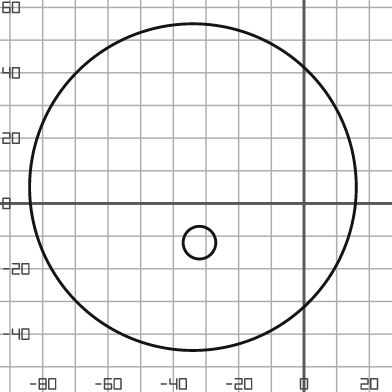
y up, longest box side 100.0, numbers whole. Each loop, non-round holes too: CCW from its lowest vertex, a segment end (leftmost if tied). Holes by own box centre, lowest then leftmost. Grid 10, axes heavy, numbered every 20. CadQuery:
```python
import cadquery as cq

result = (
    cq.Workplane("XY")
    .moveTo(-34.0, 5.0)
    .circle(50.0)
    .moveTo(-32.0, -12.0)
    .circle(5.0)
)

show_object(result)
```